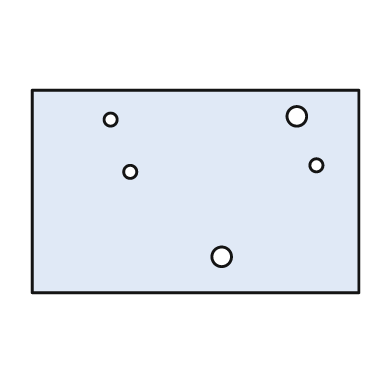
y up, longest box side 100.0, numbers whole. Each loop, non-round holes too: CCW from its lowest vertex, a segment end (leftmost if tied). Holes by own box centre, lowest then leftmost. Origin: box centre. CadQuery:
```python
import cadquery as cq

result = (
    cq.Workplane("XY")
    .moveTo(-50.0, -31.0)
    .lineTo(50.0, -31.0)
    .lineTo(50.0, 31.0)
    .lineTo(-50.0, 31.0)
    .close()
    .moveTo(8.0, -20.0)
    .circle(3.0)
    .moveTo(-20.0, 6.0)
    .circle(2.0)
    .moveTo(37.0, 8.0)
    .circle(2.0)
    .moveTo(-26.0, 22.0)
    .circle(2.0)
    .moveTo(31.0, 23.0)
    .circle(3.0)
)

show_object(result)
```